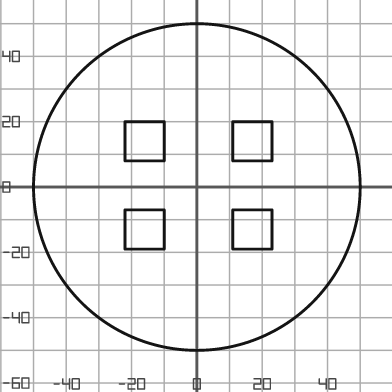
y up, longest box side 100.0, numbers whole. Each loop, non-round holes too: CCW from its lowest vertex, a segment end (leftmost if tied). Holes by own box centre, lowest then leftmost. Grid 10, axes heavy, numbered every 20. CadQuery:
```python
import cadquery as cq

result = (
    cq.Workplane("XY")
    .moveTo(0.0, 0.0)
    .circle(50.0)
    .moveTo(-22.0, -19.0)
    .lineTo(-10.0, -19.0)
    .lineTo(-10.0, -7.0)
    .lineTo(-22.0, -7.0)
    .close()
    .moveTo(11.0, -19.0)
    .lineTo(23.0, -19.0)
    .lineTo(23.0, -7.0)
    .lineTo(11.0, -7.0)
    .close()
    .moveTo(-22.0, 8.0)
    .lineTo(-10.0, 8.0)
    .lineTo(-10.0, 20.0)
    .lineTo(-22.0, 20.0)
    .close()
    .moveTo(11.0, 8.0)
    .lineTo(23.0, 8.0)
    .lineTo(23.0, 20.0)
    .lineTo(11.0, 20.0)
    .close()
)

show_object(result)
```